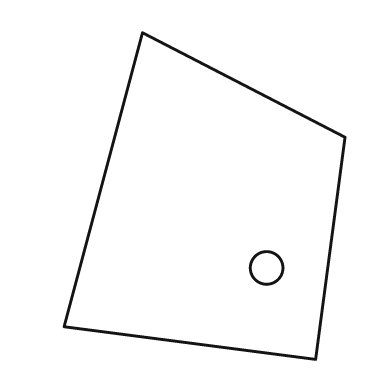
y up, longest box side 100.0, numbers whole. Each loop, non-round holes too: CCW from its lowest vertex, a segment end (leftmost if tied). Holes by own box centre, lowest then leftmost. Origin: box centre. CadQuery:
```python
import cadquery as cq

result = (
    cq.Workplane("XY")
    .moveTo(34.0, -50.0)
    .lineTo(43.0, 18.0)
    .lineTo(-19.0, 50.0)
    .lineTo(-43.0, -40.0)
    .close()
    .moveTo(19.0, -22.0)
    .circle(5.0)
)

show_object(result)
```